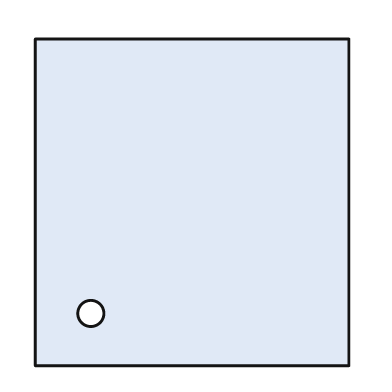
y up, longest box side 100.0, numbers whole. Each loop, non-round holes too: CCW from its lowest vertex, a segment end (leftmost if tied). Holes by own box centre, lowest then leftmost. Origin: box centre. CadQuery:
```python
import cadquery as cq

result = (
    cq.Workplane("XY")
    .moveTo(-48.0, -50.0)
    .lineTo(48.0, -50.0)
    .lineTo(48.0, 50.0)
    .lineTo(-48.0, 50.0)
    .close()
    .moveTo(-31.0, -34.0)
    .circle(4.0)
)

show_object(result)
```